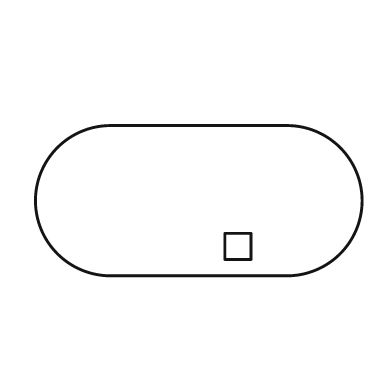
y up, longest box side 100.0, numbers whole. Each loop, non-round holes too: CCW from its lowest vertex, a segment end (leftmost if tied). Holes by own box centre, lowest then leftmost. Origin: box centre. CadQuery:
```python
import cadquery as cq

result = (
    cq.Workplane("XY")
    .moveTo(-27.0, -23.0)
    .lineTo(27.0, -23.0)
    .threePointArc((50.0, 0.0), (27.0, 23.0))
    .lineTo(-27.0, 23.0)
    .threePointArc((-50.0, 0.0), (-27.0, -23.0))
    .close()
    .moveTo(8.0, -18.0)
    .lineTo(16.0, -18.0)
    .lineTo(16.0, -10.0)
    .lineTo(8.0, -10.0)
    .close()
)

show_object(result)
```